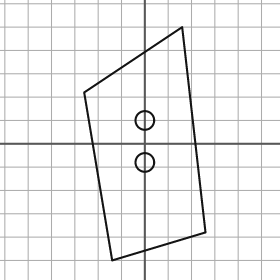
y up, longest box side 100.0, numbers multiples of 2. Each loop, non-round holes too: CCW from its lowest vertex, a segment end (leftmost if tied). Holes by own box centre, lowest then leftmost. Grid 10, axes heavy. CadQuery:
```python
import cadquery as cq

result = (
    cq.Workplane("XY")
    .moveTo(-14.0, -50.0)
    .lineTo(26.0, -38.0)
    .lineTo(16.0, 50.0)
    .lineTo(-26.0, 22.0)
    .close()
    .moveTo(0.0, -8.0)
    .circle(4.0)
    .moveTo(0.0, 10.0)
    .circle(4.0)
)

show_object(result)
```